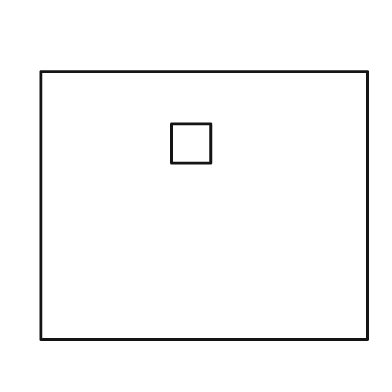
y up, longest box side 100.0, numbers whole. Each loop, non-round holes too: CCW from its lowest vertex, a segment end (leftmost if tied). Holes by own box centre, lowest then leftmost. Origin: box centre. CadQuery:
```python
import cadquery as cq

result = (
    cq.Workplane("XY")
    .moveTo(-50.0, -41.0)
    .lineTo(50.0, -41.0)
    .lineTo(50.0, 41.0)
    .lineTo(-50.0, 41.0)
    .close()
    .moveTo(-10.0, 13.0)
    .lineTo(2.0, 13.0)
    .lineTo(2.0, 25.0)
    .lineTo(-10.0, 25.0)
    .close()
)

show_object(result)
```